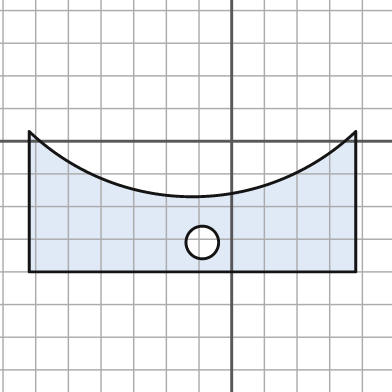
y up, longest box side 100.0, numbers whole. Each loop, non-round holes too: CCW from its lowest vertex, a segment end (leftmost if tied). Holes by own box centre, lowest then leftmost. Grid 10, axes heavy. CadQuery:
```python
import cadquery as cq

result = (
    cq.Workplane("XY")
    .moveTo(-62.0, -40.0)
    .lineTo(38.0, -40.0)
    .lineTo(38.0, 3.0)
    .threePointArc((-12.0, -17.0), (-62.0, 3.0))
    .close()
    .moveTo(-9.0, -31.0)
    .circle(5.0)
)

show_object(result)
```